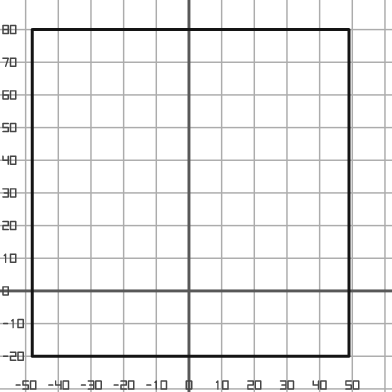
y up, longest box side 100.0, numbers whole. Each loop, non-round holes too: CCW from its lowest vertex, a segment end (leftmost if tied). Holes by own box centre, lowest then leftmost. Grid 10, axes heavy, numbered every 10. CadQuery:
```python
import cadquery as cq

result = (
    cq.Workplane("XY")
    .moveTo(-48.0, -20.0)
    .lineTo(49.0, -20.0)
    .lineTo(49.0, 80.0)
    .lineTo(-48.0, 80.0)
    .close()
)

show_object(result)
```